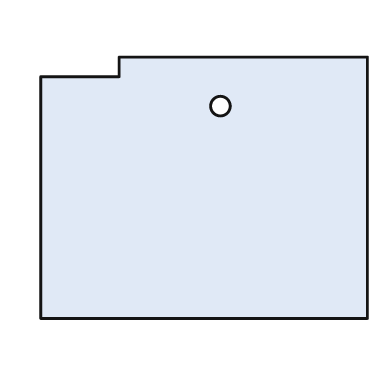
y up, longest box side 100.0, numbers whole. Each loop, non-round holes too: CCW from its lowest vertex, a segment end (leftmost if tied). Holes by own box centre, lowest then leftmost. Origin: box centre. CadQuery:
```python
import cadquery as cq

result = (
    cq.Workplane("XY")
    .moveTo(-50.0, -40.0)
    .lineTo(50.0, -40.0)
    .lineTo(50.0, 40.0)
    .lineTo(-26.0, 40.0)
    .lineTo(-26.0, 34.0)
    .lineTo(-50.0, 34.0)
    .close()
    .moveTo(5.0, 25.0)
    .circle(3.0)
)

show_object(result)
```